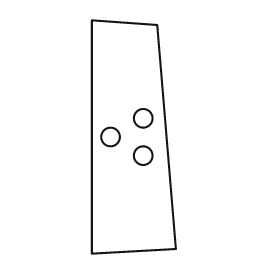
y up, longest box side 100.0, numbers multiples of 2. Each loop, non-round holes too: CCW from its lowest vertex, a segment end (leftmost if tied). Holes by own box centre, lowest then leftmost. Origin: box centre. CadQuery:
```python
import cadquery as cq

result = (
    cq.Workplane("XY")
    .moveTo(-18.0, -50.0)
    .lineTo(18.0, -48.0)
    .lineTo(10.0, 48.0)
    .lineTo(-18.0, 50.0)
    .close()
    .moveTo(4.0, -8.0)
    .circle(4.0)
    .moveTo(-10.0, 0.0)
    .circle(4.0)
    .moveTo(4.0, 8.0)
    .circle(4.0)
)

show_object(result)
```